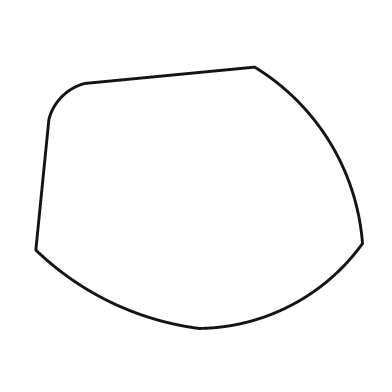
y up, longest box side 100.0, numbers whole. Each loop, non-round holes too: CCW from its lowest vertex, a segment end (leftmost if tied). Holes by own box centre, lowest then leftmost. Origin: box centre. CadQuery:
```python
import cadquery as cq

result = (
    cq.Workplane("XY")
    .moveTo(0.0, -40.0)
    .threePointArc((28.0, -33.0), (50.0, -14.0))
    .threePointArc((40.0, 17.0), (17.0, 40.0))
    .lineTo(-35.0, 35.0)
    .threePointArc((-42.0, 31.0), (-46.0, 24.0))
    .lineTo(-50.0, -16.0)
    .threePointArc((-27.0, -32.0), (0.0, -40.0))
    .close()
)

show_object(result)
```